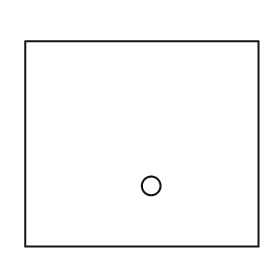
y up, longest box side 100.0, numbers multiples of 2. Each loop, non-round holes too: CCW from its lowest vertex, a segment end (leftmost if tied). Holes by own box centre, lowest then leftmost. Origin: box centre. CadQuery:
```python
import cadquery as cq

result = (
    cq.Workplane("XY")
    .moveTo(-50.0, -44.0)
    .lineTo(50.0, -44.0)
    .lineTo(50.0, 44.0)
    .lineTo(-50.0, 44.0)
    .close()
    .moveTo(4.0, -18.0)
    .circle(4.0)
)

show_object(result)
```